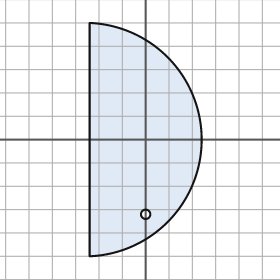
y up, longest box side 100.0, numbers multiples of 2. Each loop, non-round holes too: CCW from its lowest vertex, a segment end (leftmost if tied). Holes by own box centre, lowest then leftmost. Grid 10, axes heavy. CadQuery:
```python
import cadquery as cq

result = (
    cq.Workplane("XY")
    .moveTo(-24.0, -50.0)
    .threePointArc((24.0, 0.0), (-24.0, 50.0))
    .close()
    .moveTo(0.0, -32.0)
    .circle(2.0)
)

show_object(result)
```